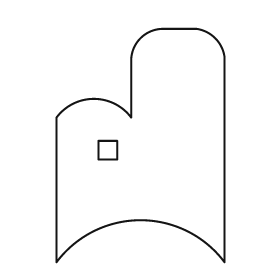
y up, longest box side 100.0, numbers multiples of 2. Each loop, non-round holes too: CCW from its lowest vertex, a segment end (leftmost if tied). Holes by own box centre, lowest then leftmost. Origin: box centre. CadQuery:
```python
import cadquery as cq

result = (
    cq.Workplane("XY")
    .moveTo(-36.0, -50.0)
    .threePointArc((0.0, -32.0), (36.0, -50.0))
    .lineTo(36.0, 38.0)
    .threePointArc((32.0, 46.0), (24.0, 50.0))
    .lineTo(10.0, 50.0)
    .threePointArc((0.0, 46.0), (-4.0, 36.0))
    .lineTo(-4.0, 12.0)
    .threePointArc((-20.0, 20.0), (-36.0, 12.0))
    .close()
    .moveTo(-18.0, -6.0)
    .lineTo(-10.0, -6.0)
    .lineTo(-10.0, 2.0)
    .lineTo(-18.0, 2.0)
    .close()
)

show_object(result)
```